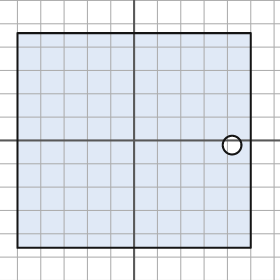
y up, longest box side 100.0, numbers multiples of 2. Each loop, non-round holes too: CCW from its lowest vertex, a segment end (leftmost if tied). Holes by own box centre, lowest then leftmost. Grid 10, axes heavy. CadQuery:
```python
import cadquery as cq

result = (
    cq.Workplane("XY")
    .moveTo(-50.0, -46.0)
    .lineTo(50.0, -46.0)
    .lineTo(50.0, 46.0)
    .lineTo(-50.0, 46.0)
    .close()
    .moveTo(42.0, -2.0)
    .circle(4.0)
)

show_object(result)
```